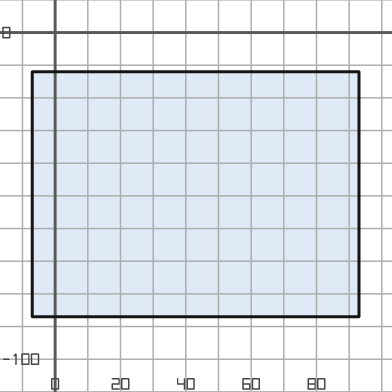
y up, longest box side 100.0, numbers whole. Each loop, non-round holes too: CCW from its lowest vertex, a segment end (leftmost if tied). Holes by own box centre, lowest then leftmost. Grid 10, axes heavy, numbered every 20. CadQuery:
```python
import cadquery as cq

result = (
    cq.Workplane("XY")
    .moveTo(-7.0, -87.0)
    .lineTo(93.0, -87.0)
    .lineTo(93.0, -12.0)
    .lineTo(-7.0, -12.0)
    .close()
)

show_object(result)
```